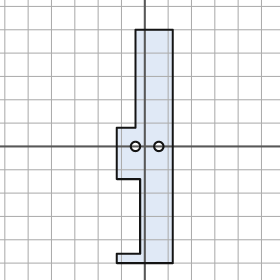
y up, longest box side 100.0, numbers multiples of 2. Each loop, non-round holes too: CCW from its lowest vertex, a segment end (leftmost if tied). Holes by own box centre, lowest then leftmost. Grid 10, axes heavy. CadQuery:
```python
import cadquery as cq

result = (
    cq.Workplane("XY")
    .moveTo(-12.0, -50.0)
    .lineTo(12.0, -50.0)
    .lineTo(12.0, 50.0)
    .lineTo(-4.0, 50.0)
    .lineTo(-4.0, 8.0)
    .lineTo(-12.0, 8.0)
    .lineTo(-12.0, -14.0)
    .lineTo(-2.0, -14.0)
    .lineTo(-2.0, -46.0)
    .lineTo(-12.0, -46.0)
    .close()
    .moveTo(-4.0, 0.0)
    .circle(2.0)
    .moveTo(6.0, 0.0)
    .circle(2.0)
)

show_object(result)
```